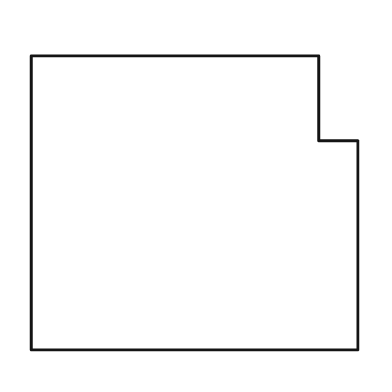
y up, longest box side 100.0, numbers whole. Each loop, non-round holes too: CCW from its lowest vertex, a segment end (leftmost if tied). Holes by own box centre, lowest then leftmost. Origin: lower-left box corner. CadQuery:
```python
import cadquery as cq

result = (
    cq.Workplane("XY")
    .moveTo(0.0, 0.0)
    .lineTo(100.0, 0.0)
    .lineTo(100.0, 64.0)
    .lineTo(88.0, 64.0)
    .lineTo(88.0, 90.0)
    .lineTo(0.0, 90.0)
    .close()
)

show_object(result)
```